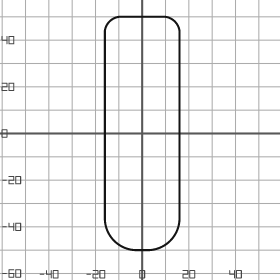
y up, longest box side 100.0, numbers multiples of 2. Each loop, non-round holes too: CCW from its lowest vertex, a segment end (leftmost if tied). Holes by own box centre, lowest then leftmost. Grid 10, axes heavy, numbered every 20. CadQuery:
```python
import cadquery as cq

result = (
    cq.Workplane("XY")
    .moveTo(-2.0, -50.0)
    .lineTo(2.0, -50.0)
    .threePointArc((12.0, -46.0), (16.0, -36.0))
    .lineTo(16.0, 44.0)
    .threePointArc((14.0, 48.0), (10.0, 50.0))
    .lineTo(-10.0, 50.0)
    .threePointArc((-14.0, 48.0), (-16.0, 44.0))
    .lineTo(-16.0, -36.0)
    .threePointArc((-12.0, -46.0), (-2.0, -50.0))
    .close()
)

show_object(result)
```